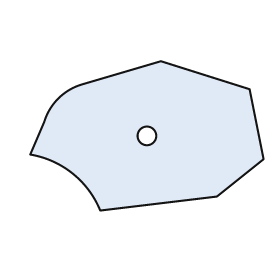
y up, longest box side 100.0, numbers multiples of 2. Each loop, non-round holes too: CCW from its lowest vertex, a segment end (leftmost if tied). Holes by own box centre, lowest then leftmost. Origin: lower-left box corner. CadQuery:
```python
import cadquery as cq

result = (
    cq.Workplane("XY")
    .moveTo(30.0, 0.0)
    .lineTo(80.0, 6.0)
    .lineTo(100.0, 22.0)
    .lineTo(94.0, 52.0)
    .lineTo(56.0, 64.0)
    .lineTo(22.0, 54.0)
    .threePointArc((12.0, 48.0), (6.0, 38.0))
    .lineTo(0.0, 24.0)
    .threePointArc((18.0, 16.0), (30.0, 0.0))
    .close()
    .moveTo(50.0, 32.0)
    .circle(4.0)
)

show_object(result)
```